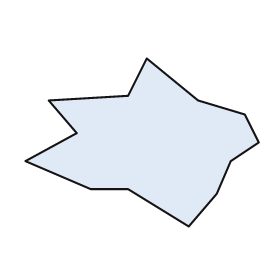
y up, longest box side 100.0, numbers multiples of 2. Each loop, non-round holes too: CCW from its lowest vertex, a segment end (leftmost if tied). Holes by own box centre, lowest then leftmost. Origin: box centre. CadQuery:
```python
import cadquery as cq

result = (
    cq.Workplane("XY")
    .moveTo(20.0, -36.0)
    .lineTo(32.0, -22.0)
    .lineTo(38.0, -8.0)
    .lineTo(50.0, 0.0)
    .lineTo(44.0, 12.0)
    .lineTo(24.0, 18.0)
    .lineTo(2.0, 36.0)
    .lineTo(-6.0, 20.0)
    .lineTo(-40.0, 18.0)
    .lineTo(-28.0, 4.0)
    .lineTo(-50.0, -8.0)
    .lineTo(-22.0, -20.0)
    .lineTo(-6.0, -20.0)
    .close()
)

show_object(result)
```